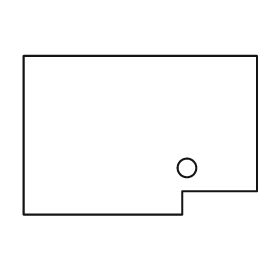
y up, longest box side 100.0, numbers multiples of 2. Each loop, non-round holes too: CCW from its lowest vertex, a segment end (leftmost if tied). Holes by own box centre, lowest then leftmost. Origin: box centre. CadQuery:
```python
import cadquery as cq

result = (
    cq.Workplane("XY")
    .moveTo(-50.0, -34.0)
    .lineTo(18.0, -34.0)
    .lineTo(18.0, -24.0)
    .lineTo(50.0, -24.0)
    .lineTo(50.0, 34.0)
    .lineTo(-50.0, 34.0)
    .close()
    .moveTo(20.0, -14.0)
    .circle(4.0)
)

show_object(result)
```